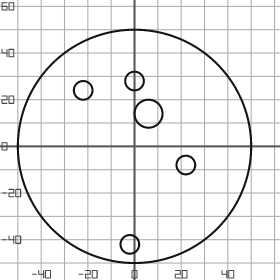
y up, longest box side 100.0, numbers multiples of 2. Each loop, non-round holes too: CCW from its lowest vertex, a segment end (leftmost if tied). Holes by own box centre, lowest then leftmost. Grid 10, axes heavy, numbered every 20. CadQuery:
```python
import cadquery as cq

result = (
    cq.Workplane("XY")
    .moveTo(0.0, 0.0)
    .circle(50.0)
    .moveTo(-2.0, -42.0)
    .circle(4.0)
    .moveTo(22.0, -8.0)
    .circle(4.0)
    .moveTo(6.0, 14.0)
    .circle(6.0)
    .moveTo(-22.0, 24.0)
    .circle(4.0)
    .moveTo(0.0, 28.0)
    .circle(4.0)
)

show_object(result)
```